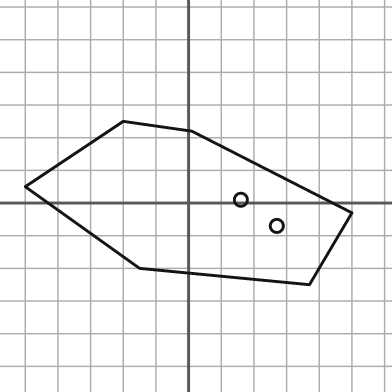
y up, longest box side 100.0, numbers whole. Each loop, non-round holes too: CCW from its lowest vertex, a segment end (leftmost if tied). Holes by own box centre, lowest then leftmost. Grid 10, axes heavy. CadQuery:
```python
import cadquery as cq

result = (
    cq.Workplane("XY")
    .moveTo(37.0, -25.0)
    .lineTo(50.0, -3.0)
    .lineTo(1.0, 22.0)
    .lineTo(-20.0, 25.0)
    .lineTo(-50.0, 5.0)
    .lineTo(-15.0, -20.0)
    .close()
    .moveTo(27.0, -7.0)
    .circle(2.0)
    .moveTo(16.0, 1.0)
    .circle(2.0)
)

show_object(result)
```